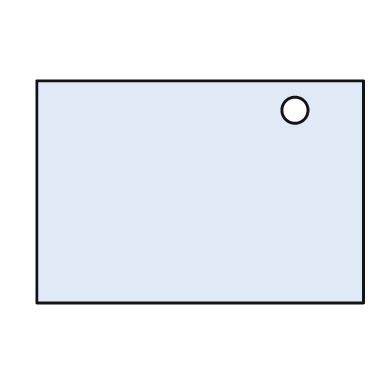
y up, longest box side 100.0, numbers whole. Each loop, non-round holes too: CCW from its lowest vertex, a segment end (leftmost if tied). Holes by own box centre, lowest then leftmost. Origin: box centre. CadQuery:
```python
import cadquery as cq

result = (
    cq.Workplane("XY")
    .moveTo(-50.0, -34.0)
    .lineTo(50.0, -34.0)
    .lineTo(50.0, 34.0)
    .lineTo(-50.0, 34.0)
    .close()
    .moveTo(29.0, 25.0)
    .circle(4.0)
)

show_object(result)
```